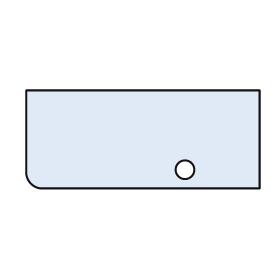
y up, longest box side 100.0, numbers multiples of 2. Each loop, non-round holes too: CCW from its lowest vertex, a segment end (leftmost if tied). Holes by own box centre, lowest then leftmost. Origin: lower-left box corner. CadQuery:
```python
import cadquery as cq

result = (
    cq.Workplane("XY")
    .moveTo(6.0, 0.0)
    .lineTo(100.0, 0.0)
    .lineTo(100.0, 42.0)
    .lineTo(0.0, 42.0)
    .lineTo(0.0, 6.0)
    .threePointArc((2.0, 2.0), (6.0, 0.0))
    .close()
    .moveTo(68.0, 8.0)
    .circle(4.0)
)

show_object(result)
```